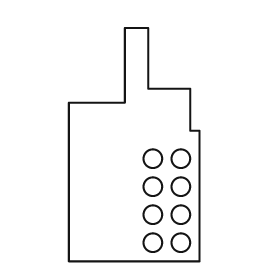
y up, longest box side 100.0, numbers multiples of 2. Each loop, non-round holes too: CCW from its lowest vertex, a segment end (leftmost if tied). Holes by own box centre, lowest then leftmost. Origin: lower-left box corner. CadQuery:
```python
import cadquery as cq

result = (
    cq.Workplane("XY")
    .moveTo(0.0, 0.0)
    .lineTo(56.0, 0.0)
    .lineTo(56.0, 56.0)
    .lineTo(52.0, 56.0)
    .lineTo(52.0, 74.0)
    .lineTo(34.0, 74.0)
    .lineTo(34.0, 100.0)
    .lineTo(24.0, 100.0)
    .lineTo(24.0, 68.0)
    .lineTo(0.0, 68.0)
    .close()
    .moveTo(36.0, 8.0)
    .circle(4.0)
    .moveTo(48.0, 8.0)
    .circle(4.0)
    .moveTo(36.0, 20.0)
    .circle(4.0)
    .moveTo(48.0, 20.0)
    .circle(4.0)
    .moveTo(36.0, 32.0)
    .circle(4.0)
    .moveTo(48.0, 32.0)
    .circle(4.0)
    .moveTo(36.0, 44.0)
    .circle(4.0)
    .moveTo(48.0, 44.0)
    .circle(4.0)
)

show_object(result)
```